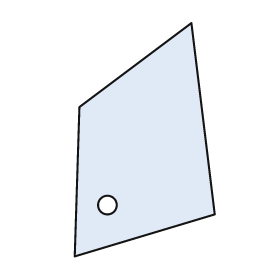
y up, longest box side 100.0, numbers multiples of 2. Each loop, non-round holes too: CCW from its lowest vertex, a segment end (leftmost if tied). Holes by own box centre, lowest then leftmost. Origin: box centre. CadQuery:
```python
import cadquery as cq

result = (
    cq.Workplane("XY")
    .moveTo(-30.0, -50.0)
    .lineTo(30.0, -32.0)
    .lineTo(20.0, 50.0)
    .lineTo(-28.0, 14.0)
    .close()
    .moveTo(-16.0, -28.0)
    .circle(4.0)
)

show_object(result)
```